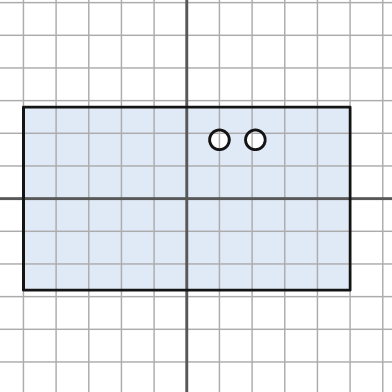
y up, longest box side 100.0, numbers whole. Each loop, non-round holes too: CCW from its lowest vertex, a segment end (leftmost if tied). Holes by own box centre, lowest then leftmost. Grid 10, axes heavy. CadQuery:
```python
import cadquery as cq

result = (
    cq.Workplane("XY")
    .moveTo(-50.0, -28.0)
    .lineTo(50.0, -28.0)
    .lineTo(50.0, 28.0)
    .lineTo(-50.0, 28.0)
    .close()
    .moveTo(10.0, 18.0)
    .circle(3.0)
    .moveTo(21.0, 18.0)
    .circle(3.0)
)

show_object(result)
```